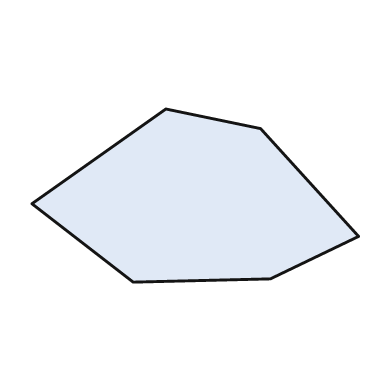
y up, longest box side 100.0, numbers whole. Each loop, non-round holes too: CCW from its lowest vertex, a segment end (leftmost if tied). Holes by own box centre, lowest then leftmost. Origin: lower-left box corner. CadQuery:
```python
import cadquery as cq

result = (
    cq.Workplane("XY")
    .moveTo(31.0, 0.0)
    .lineTo(73.0, 1.0)
    .lineTo(100.0, 14.0)
    .lineTo(70.0, 47.0)
    .lineTo(41.0, 53.0)
    .lineTo(0.0, 24.0)
    .close()
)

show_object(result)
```